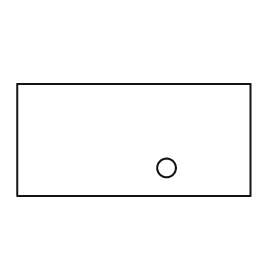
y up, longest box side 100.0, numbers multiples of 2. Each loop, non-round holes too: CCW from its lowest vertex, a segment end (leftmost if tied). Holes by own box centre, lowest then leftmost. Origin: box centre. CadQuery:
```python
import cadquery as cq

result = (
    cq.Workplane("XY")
    .moveTo(-50.0, -24.0)
    .lineTo(50.0, -24.0)
    .lineTo(50.0, 24.0)
    .lineTo(-50.0, 24.0)
    .close()
    .moveTo(14.0, -12.0)
    .circle(4.0)
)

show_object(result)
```